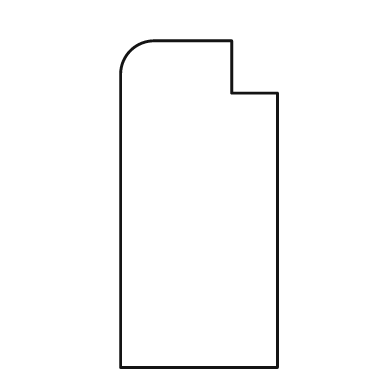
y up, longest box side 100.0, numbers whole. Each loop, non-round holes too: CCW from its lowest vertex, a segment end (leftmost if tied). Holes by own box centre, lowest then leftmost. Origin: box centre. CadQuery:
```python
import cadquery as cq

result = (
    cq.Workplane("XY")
    .moveTo(-24.0, -50.0)
    .lineTo(24.0, -50.0)
    .lineTo(24.0, 34.0)
    .lineTo(10.0, 34.0)
    .lineTo(10.0, 50.0)
    .lineTo(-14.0, 50.0)
    .threePointArc((-21.0, 47.0), (-24.0, 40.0))
    .close()
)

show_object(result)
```